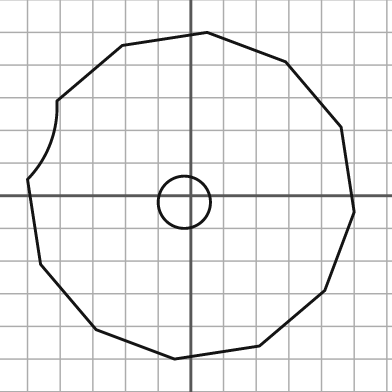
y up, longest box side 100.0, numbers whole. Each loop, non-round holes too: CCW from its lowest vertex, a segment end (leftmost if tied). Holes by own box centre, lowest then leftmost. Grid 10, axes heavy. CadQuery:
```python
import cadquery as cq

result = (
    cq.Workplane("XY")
    .moveTo(-5.0, -50.0)
    .lineTo(21.0, -46.0)
    .lineTo(41.0, -29.0)
    .lineTo(50.0, -5.0)
    .lineTo(46.0, 21.0)
    .lineTo(29.0, 41.0)
    .lineTo(5.0, 50.0)
    .lineTo(-21.0, 46.0)
    .lineTo(-41.0, 29.0)
    .threePointArc((-43.0, 16.0), (-50.0, 5.0))
    .lineTo(-46.0, -21.0)
    .lineTo(-29.0, -41.0)
    .close()
    .moveTo(-2.0, -2.0)
    .circle(8.0)
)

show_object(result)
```